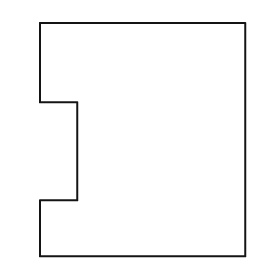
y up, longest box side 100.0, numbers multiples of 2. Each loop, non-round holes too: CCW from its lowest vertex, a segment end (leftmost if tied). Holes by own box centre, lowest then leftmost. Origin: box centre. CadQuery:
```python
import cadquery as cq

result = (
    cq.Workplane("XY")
    .moveTo(-44.0, -50.0)
    .lineTo(44.0, -50.0)
    .lineTo(44.0, 50.0)
    .lineTo(-44.0, 50.0)
    .lineTo(-44.0, 16.0)
    .lineTo(-28.0, 16.0)
    .lineTo(-28.0, -26.0)
    .lineTo(-44.0, -26.0)
    .close()
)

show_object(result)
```